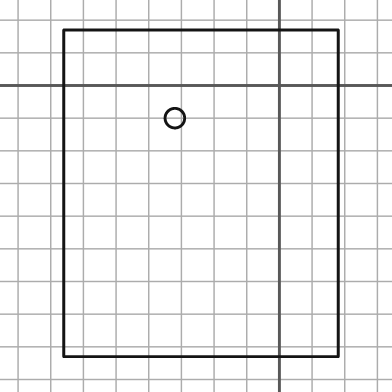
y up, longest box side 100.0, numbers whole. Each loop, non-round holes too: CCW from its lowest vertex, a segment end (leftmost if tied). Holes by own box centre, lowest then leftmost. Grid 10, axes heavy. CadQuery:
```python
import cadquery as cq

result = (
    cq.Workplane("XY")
    .moveTo(-66.0, -83.0)
    .lineTo(18.0, -83.0)
    .lineTo(18.0, 17.0)
    .lineTo(-66.0, 17.0)
    .close()
    .moveTo(-32.0, -10.0)
    .circle(3.0)
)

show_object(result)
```